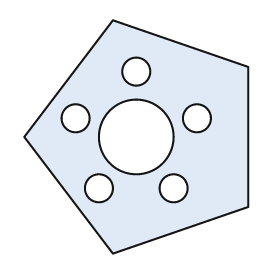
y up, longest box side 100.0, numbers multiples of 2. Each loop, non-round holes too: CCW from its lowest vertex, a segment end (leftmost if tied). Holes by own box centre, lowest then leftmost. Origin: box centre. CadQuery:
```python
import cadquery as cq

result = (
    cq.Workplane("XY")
    .moveTo(-10.0, -50.0)
    .lineTo(48.0, -30.0)
    .lineTo(48.0, 30.0)
    .lineTo(-10.0, 50.0)
    .lineTo(-48.0, 0.0)
    .close()
    .moveTo(-16.0, -22.0)
    .circle(6.0)
    .moveTo(16.0, -22.0)
    .circle(6.0)
    .moveTo(0.0, 0.0)
    .circle(16.0)
    .moveTo(-26.0, 8.0)
    .circle(6.0)
    .moveTo(26.0, 8.0)
    .circle(6.0)
    .moveTo(0.0, 28.0)
    .circle(6.0)
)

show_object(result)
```